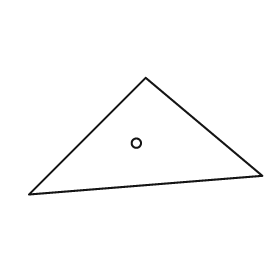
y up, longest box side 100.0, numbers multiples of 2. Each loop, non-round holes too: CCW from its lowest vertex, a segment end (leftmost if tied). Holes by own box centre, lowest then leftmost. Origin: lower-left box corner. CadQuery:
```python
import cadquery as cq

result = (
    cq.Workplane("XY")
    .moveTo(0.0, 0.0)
    .lineTo(100.0, 8.0)
    .lineTo(50.0, 50.0)
    .close()
    .moveTo(46.0, 22.0)
    .circle(2.0)
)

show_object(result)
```